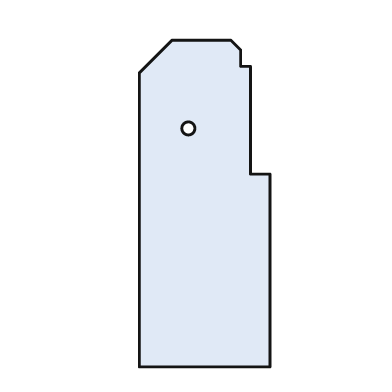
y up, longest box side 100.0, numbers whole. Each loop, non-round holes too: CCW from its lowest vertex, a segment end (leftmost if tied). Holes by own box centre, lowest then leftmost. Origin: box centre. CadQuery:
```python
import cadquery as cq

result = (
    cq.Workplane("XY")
    .moveTo(-20.0, -50.0)
    .lineTo(20.0, -50.0)
    .lineTo(20.0, 9.0)
    .lineTo(14.0, 9.0)
    .lineTo(14.0, 42.0)
    .lineTo(11.0, 42.0)
    .lineTo(11.0, 47.0)
    .lineTo(8.0, 50.0)
    .lineTo(-10.0, 50.0)
    .lineTo(-20.0, 40.0)
    .close()
    .moveTo(-5.0, 23.0)
    .circle(2.0)
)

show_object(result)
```